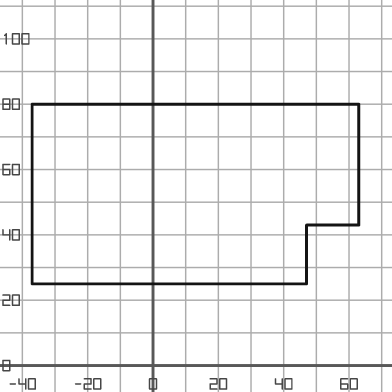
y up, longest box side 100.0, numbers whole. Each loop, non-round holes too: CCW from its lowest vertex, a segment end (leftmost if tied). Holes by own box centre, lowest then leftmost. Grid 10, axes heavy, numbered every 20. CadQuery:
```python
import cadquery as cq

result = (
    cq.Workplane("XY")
    .moveTo(-37.0, 25.0)
    .lineTo(47.0, 25.0)
    .lineTo(47.0, 43.0)
    .lineTo(63.0, 43.0)
    .lineTo(63.0, 80.0)
    .lineTo(-37.0, 80.0)
    .close()
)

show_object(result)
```